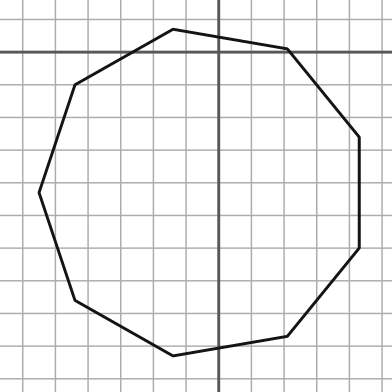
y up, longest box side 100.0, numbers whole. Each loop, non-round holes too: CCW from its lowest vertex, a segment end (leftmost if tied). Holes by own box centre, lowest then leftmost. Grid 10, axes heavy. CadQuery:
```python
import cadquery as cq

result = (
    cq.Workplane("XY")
    .moveTo(-14.0, -93.0)
    .lineTo(21.0, -87.0)
    .lineTo(43.0, -60.0)
    .lineTo(43.0, -26.0)
    .lineTo(21.0, 1.0)
    .lineTo(-14.0, 7.0)
    .lineTo(-44.0, -10.0)
    .lineTo(-55.0, -43.0)
    .lineTo(-44.0, -76.0)
    .close()
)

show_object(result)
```